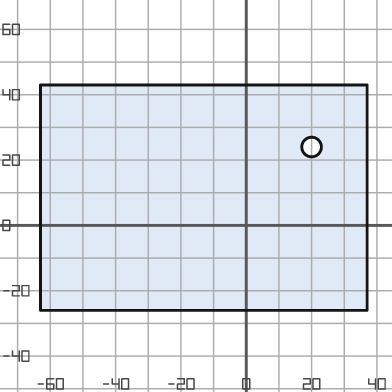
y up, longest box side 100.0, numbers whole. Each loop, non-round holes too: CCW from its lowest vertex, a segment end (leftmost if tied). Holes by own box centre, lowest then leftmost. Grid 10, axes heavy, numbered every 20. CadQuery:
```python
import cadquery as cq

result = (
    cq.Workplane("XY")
    .moveTo(-63.0, -26.0)
    .lineTo(37.0, -26.0)
    .lineTo(37.0, 43.0)
    .lineTo(-63.0, 43.0)
    .close()
    .moveTo(20.0, 24.0)
    .circle(3.0)
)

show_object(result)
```